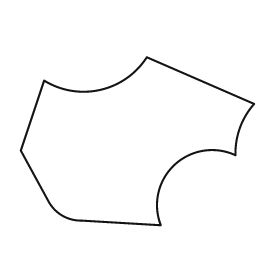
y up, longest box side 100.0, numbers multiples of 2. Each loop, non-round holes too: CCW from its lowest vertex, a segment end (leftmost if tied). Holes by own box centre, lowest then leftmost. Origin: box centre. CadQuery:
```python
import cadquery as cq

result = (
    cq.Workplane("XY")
    .moveTo(10.0, -36.0)
    .threePointArc((16.0, -10.0), (42.0, -6.0))
    .threePointArc((44.0, 6.0), (50.0, 16.0))
    .lineTo(4.0, 36.0)
    .threePointArc((-16.0, 22.0), (-40.0, 26.0))
    .lineTo(-50.0, -4.0)
    .lineTo(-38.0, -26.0)
    .threePointArc((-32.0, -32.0), (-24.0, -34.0))
    .close()
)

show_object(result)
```